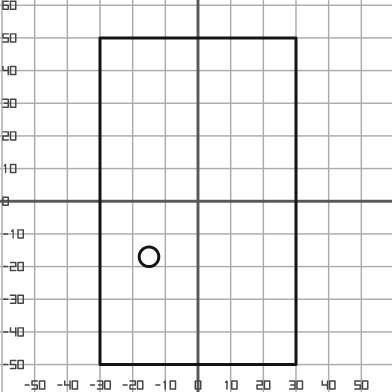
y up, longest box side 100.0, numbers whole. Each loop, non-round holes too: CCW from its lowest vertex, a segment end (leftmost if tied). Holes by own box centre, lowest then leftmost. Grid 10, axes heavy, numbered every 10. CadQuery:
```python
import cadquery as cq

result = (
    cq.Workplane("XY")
    .moveTo(-30.0, -50.0)
    .lineTo(30.0, -50.0)
    .lineTo(30.0, 50.0)
    .lineTo(-30.0, 50.0)
    .close()
    .moveTo(-15.0, -17.0)
    .circle(3.0)
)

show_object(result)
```